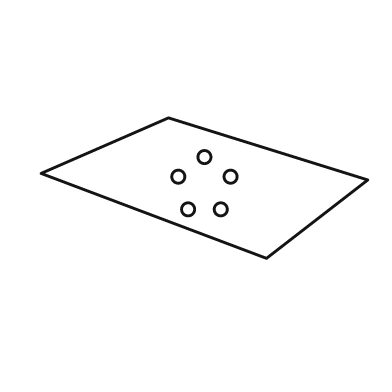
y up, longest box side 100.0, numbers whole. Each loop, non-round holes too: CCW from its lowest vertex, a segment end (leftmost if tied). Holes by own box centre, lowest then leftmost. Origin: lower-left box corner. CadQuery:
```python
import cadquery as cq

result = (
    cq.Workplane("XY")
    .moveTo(69.0, 0.0)
    .lineTo(100.0, 24.0)
    .lineTo(39.0, 43.0)
    .lineTo(0.0, 26.0)
    .close()
    .moveTo(45.0, 15.0)
    .circle(2.0)
    .moveTo(55.0, 15.0)
    .circle(2.0)
    .moveTo(42.0, 25.0)
    .circle(2.0)
    .moveTo(58.0, 25.0)
    .circle(2.0)
    .moveTo(50.0, 31.0)
    .circle(2.0)
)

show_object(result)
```